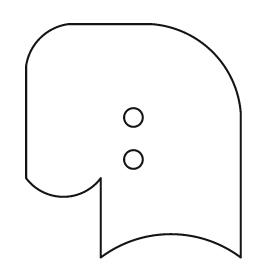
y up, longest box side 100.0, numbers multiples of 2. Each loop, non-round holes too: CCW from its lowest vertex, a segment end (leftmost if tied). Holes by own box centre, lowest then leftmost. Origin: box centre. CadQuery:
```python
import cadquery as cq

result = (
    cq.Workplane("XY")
    .moveTo(-14.0, -50.0)
    .threePointArc((16.0, -40.0), (46.0, -50.0))
    .lineTo(46.0, 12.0)
    .threePointArc((34.0, 38.0), (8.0, 50.0))
    .lineTo(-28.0, 50.0)
    .threePointArc((-40.0, 44.0), (-46.0, 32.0))
    .lineTo(-46.0, -16.0)
    .threePointArc((-30.0, -24.0), (-14.0, -16.0))
    .close()
    .moveTo(0.0, -8.0)
    .circle(4.0)
    .moveTo(0.0, 10.0)
    .circle(4.0)
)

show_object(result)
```